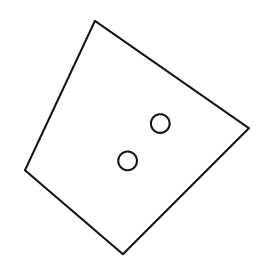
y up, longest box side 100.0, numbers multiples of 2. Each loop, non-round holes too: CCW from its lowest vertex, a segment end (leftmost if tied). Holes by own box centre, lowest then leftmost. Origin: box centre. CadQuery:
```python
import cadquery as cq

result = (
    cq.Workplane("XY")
    .moveTo(-6.0, -50.0)
    .lineTo(48.0, 4.0)
    .lineTo(-18.0, 50.0)
    .lineTo(-48.0, -14.0)
    .close()
    .moveTo(-4.0, -10.0)
    .circle(4.0)
    .moveTo(10.0, 6.0)
    .circle(4.0)
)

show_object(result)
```